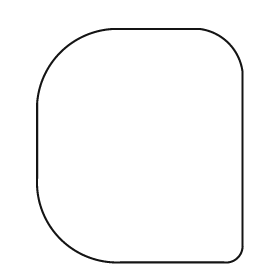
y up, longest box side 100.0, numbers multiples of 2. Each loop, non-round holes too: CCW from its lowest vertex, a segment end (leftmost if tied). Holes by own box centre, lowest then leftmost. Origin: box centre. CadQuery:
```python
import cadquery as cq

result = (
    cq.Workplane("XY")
    .moveTo(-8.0, -50.0)
    .lineTo(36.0, -50.0)
    .threePointArc((42.0, -48.0), (44.0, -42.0))
    .lineTo(44.0, 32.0)
    .threePointArc((38.0, 44.0), (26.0, 50.0))
    .lineTo(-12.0, 50.0)
    .threePointArc((-34.0, 40.0), (-44.0, 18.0))
    .lineTo(-44.0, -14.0)
    .threePointArc((-34.0, -40.0), (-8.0, -50.0))
    .close()
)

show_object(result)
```